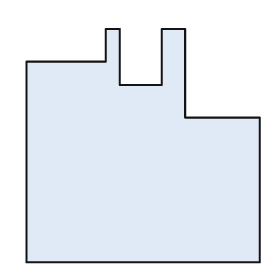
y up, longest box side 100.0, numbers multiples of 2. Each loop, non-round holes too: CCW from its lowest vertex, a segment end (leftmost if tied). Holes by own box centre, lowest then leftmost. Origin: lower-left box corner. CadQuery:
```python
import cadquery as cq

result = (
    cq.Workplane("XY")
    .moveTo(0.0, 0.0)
    .lineTo(100.0, 0.0)
    .lineTo(100.0, 62.0)
    .lineTo(68.0, 62.0)
    .lineTo(68.0, 100.0)
    .lineTo(58.0, 100.0)
    .lineTo(58.0, 76.0)
    .lineTo(40.0, 76.0)
    .lineTo(40.0, 100.0)
    .lineTo(34.0, 100.0)
    .lineTo(34.0, 86.0)
    .lineTo(0.0, 86.0)
    .close()
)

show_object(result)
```